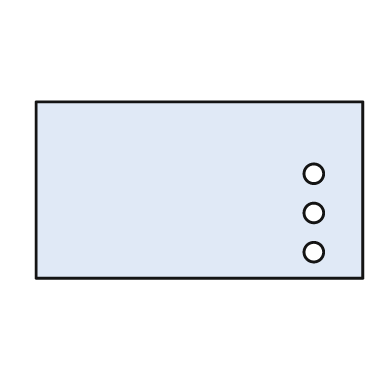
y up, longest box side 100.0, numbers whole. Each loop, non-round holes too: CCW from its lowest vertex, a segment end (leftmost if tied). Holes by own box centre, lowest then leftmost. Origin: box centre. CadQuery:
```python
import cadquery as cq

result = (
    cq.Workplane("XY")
    .moveTo(-50.0, -27.0)
    .lineTo(50.0, -27.0)
    .lineTo(50.0, 27.0)
    .lineTo(-50.0, 27.0)
    .close()
    .moveTo(35.0, -19.0)
    .circle(3.0)
    .moveTo(35.0, -7.0)
    .circle(3.0)
    .moveTo(35.0, 5.0)
    .circle(3.0)
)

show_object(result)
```